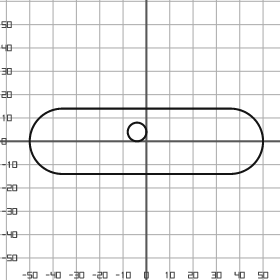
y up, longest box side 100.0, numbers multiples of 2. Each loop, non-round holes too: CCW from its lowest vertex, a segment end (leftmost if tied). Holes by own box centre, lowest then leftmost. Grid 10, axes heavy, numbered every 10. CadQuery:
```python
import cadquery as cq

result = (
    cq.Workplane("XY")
    .moveTo(-36.0, -14.0)
    .lineTo(36.0, -14.0)
    .threePointArc((50.0, 0.0), (36.0, 14.0))
    .lineTo(-36.0, 14.0)
    .threePointArc((-50.0, 0.0), (-36.0, -14.0))
    .close()
    .moveTo(-4.0, 4.0)
    .circle(4.0)
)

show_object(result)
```